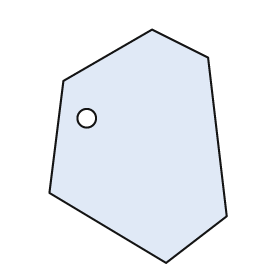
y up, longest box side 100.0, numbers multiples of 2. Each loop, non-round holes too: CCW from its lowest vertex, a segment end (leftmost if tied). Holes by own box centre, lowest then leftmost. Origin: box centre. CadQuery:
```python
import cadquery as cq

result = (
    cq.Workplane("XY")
    .moveTo(12.0, -50.0)
    .lineTo(38.0, -30.0)
    .lineTo(30.0, 38.0)
    .lineTo(6.0, 50.0)
    .lineTo(-32.0, 28.0)
    .lineTo(-38.0, -20.0)
    .close()
    .moveTo(-22.0, 12.0)
    .circle(4.0)
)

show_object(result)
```